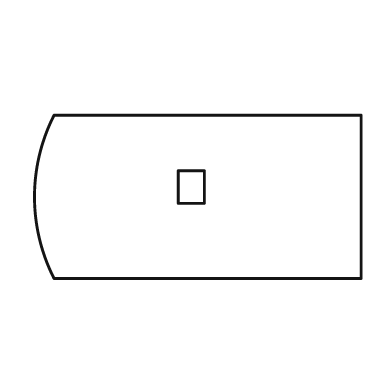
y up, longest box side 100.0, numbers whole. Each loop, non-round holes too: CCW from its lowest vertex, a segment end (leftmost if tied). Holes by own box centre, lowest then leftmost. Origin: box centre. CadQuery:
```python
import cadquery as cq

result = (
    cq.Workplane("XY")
    .moveTo(-44.0, -25.0)
    .lineTo(50.0, -25.0)
    .lineTo(50.0, 25.0)
    .lineTo(-44.0, 25.0)
    .threePointArc((-50.0, 0.0), (-44.0, -25.0))
    .close()
    .moveTo(-6.0, -2.0)
    .lineTo(2.0, -2.0)
    .lineTo(2.0, 8.0)
    .lineTo(-6.0, 8.0)
    .close()
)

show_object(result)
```